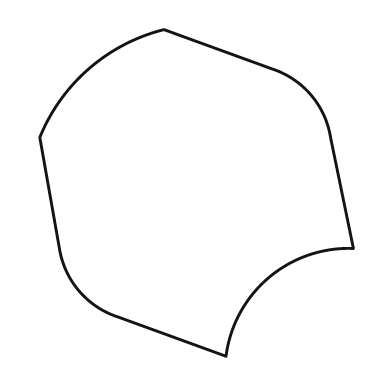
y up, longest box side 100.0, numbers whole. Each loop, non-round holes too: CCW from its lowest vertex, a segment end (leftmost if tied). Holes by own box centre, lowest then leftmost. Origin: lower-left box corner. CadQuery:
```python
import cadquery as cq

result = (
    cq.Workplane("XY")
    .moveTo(57.0, 0.0)
    .threePointArc((70.0, 24.0), (96.0, 33.0))
    .lineTo(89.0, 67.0)
    .threePointArc((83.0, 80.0), (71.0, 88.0))
    .lineTo(38.0, 100.0)
    .threePointArc((15.0, 88.0), (0.0, 67.0))
    .lineTo(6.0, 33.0)
    .threePointArc((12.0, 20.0), (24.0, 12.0))
    .close()
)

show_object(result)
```